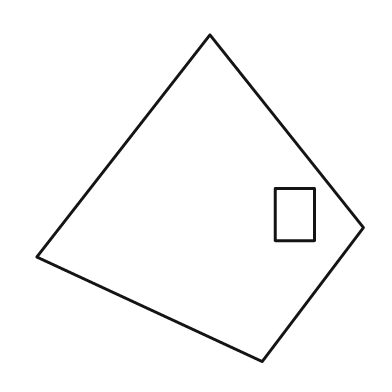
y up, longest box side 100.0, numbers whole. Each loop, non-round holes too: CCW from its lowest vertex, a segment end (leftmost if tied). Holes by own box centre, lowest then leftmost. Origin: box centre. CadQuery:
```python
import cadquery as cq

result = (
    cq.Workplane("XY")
    .moveTo(19.0, -50.0)
    .lineTo(50.0, -9.0)
    .lineTo(3.0, 50.0)
    .lineTo(-50.0, -18.0)
    .close()
    .moveTo(23.0, -13.0)
    .lineTo(35.0, -13.0)
    .lineTo(35.0, 3.0)
    .lineTo(23.0, 3.0)
    .close()
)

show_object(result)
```